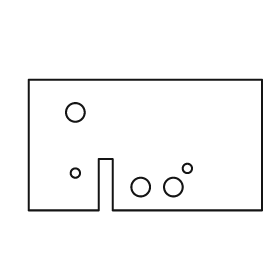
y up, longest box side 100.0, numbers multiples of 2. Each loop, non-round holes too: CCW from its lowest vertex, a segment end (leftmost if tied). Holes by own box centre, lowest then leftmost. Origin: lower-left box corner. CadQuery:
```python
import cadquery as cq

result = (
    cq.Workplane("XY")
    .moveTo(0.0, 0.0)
    .lineTo(30.0, 0.0)
    .lineTo(30.0, 22.0)
    .lineTo(36.0, 22.0)
    .lineTo(36.0, 0.0)
    .lineTo(100.0, 0.0)
    .lineTo(100.0, 56.0)
    .lineTo(0.0, 56.0)
    .close()
    .moveTo(48.0, 10.0)
    .circle(4.0)
    .moveTo(62.0, 10.0)
    .circle(4.0)
    .moveTo(20.0, 16.0)
    .circle(2.0)
    .moveTo(68.0, 18.0)
    .circle(2.0)
    .moveTo(20.0, 42.0)
    .circle(4.0)
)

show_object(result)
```